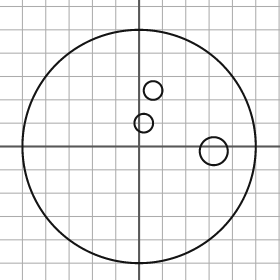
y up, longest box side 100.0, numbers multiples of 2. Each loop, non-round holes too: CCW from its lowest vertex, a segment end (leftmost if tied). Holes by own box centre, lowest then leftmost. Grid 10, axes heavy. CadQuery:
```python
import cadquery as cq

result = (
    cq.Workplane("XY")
    .moveTo(0.0, 0.0)
    .circle(50.0)
    .moveTo(32.0, -2.0)
    .circle(6.0)
    .moveTo(2.0, 10.0)
    .circle(4.0)
    .moveTo(6.0, 24.0)
    .circle(4.0)
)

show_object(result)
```